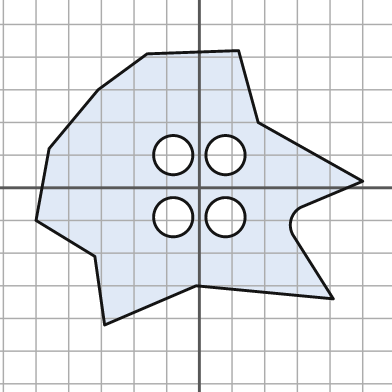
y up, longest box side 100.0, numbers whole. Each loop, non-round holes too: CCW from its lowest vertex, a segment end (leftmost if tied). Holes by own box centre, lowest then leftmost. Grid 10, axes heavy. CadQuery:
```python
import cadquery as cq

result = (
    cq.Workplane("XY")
    .moveTo(-29.0, -42.0)
    .lineTo(-1.0, -30.0)
    .lineTo(41.0, -34.0)
    .lineTo(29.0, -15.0)
    .threePointArc((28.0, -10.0), (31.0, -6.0))
    .lineTo(50.0, 2.0)
    .lineTo(18.0, 20.0)
    .lineTo(12.0, 42.0)
    .lineTo(-16.0, 41.0)
    .lineTo(-31.0, 30.0)
    .lineTo(-46.0, 12.0)
    .lineTo(-50.0, -10.0)
    .lineTo(-32.0, -21.0)
    .close()
    .moveTo(-8.0, -9.0)
    .circle(6.0)
    .moveTo(8.0, -9.0)
    .circle(6.0)
    .moveTo(-8.0, 10.0)
    .circle(6.0)
    .moveTo(8.0, 10.0)
    .circle(6.0)
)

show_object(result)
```